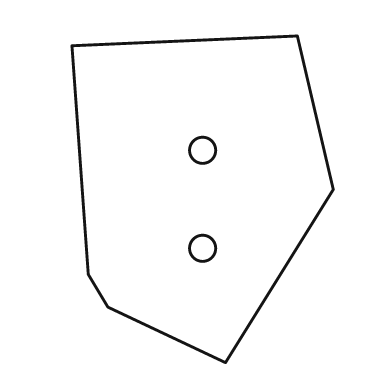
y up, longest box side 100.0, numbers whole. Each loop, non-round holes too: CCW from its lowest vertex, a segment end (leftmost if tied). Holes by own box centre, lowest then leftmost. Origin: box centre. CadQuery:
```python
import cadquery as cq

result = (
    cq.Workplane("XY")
    .moveTo(7.0, -50.0)
    .lineTo(40.0, 3.0)
    .lineTo(29.0, 50.0)
    .lineTo(-40.0, 47.0)
    .lineTo(-35.0, -23.0)
    .lineTo(-29.0, -33.0)
    .close()
    .moveTo(0.0, -15.0)
    .circle(4.0)
    .moveTo(0.0, 15.0)
    .circle(4.0)
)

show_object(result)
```